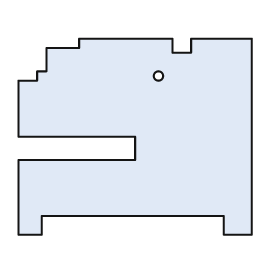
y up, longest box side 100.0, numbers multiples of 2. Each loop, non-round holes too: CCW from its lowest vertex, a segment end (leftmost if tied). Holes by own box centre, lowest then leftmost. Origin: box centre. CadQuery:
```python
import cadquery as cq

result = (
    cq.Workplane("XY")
    .moveTo(-50.0, -42.0)
    .lineTo(-40.0, -42.0)
    .lineTo(-40.0, -34.0)
    .lineTo(38.0, -34.0)
    .lineTo(38.0, -42.0)
    .lineTo(50.0, -42.0)
    .lineTo(50.0, 42.0)
    .lineTo(24.0, 42.0)
    .lineTo(24.0, 36.0)
    .lineTo(16.0, 36.0)
    .lineTo(16.0, 42.0)
    .lineTo(-24.0, 42.0)
    .lineTo(-24.0, 38.0)
    .lineTo(-38.0, 38.0)
    .lineTo(-38.0, 28.0)
    .lineTo(-42.0, 28.0)
    .lineTo(-42.0, 24.0)
    .lineTo(-50.0, 24.0)
    .lineTo(-50.0, 0.0)
    .lineTo(0.0, 0.0)
    .lineTo(0.0, -10.0)
    .lineTo(-50.0, -10.0)
    .close()
    .moveTo(10.0, 26.0)
    .circle(2.0)
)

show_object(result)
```